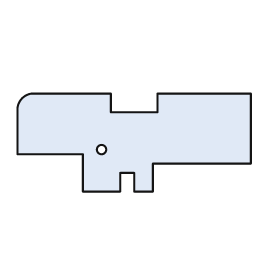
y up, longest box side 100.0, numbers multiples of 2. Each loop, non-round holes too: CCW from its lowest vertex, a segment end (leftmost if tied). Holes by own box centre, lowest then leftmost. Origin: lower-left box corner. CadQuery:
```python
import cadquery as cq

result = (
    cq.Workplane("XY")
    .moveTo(28.0, 0.0)
    .lineTo(44.0, 0.0)
    .lineTo(44.0, 8.0)
    .lineTo(50.0, 8.0)
    .lineTo(50.0, 0.0)
    .lineTo(58.0, 0.0)
    .lineTo(58.0, 12.0)
    .lineTo(100.0, 12.0)
    .lineTo(100.0, 42.0)
    .lineTo(60.0, 42.0)
    .lineTo(60.0, 34.0)
    .lineTo(40.0, 34.0)
    .lineTo(40.0, 42.0)
    .lineTo(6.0, 42.0)
    .threePointArc((2.0, 40.0), (0.0, 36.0))
    .lineTo(0.0, 16.0)
    .lineTo(28.0, 16.0)
    .close()
    .moveTo(36.0, 18.0)
    .circle(2.0)
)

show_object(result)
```